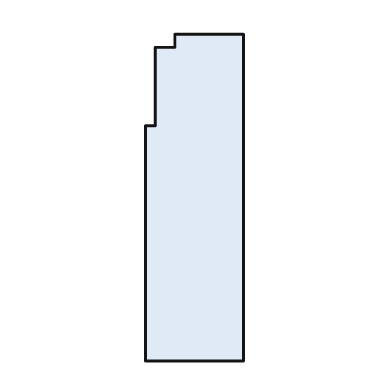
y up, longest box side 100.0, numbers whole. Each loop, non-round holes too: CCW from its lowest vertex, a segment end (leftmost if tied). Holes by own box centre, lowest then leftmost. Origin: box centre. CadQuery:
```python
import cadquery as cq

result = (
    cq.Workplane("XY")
    .moveTo(-15.0, -50.0)
    .lineTo(15.0, -50.0)
    .lineTo(15.0, 50.0)
    .lineTo(-6.0, 50.0)
    .lineTo(-6.0, 46.0)
    .lineTo(-12.0, 46.0)
    .lineTo(-12.0, 22.0)
    .lineTo(-15.0, 22.0)
    .close()
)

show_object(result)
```